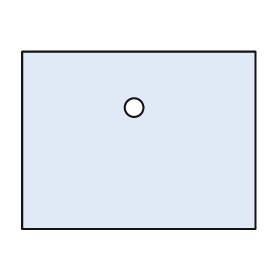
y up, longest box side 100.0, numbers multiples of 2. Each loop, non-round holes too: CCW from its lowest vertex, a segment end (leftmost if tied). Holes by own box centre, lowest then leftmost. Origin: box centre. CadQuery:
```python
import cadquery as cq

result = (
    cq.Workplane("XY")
    .moveTo(-50.0, -38.0)
    .lineTo(50.0, -38.0)
    .lineTo(50.0, 38.0)
    .lineTo(-50.0, 38.0)
    .close()
    .moveTo(-2.0, 14.0)
    .circle(4.0)
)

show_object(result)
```